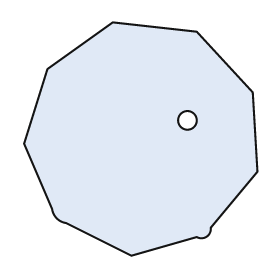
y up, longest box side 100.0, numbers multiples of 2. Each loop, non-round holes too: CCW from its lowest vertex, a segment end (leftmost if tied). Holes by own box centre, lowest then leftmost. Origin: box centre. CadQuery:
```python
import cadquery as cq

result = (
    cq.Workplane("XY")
    .moveTo(-4.0, -50.0)
    .lineTo(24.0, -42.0)
    .threePointArc((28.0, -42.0), (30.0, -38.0))
    .lineTo(50.0, -14.0)
    .lineTo(48.0, 20.0)
    .lineTo(24.0, 46.0)
    .lineTo(-12.0, 50.0)
    .lineTo(-40.0, 30.0)
    .lineTo(-50.0, -2.0)
    .lineTo(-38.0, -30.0)
    .threePointArc((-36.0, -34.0), (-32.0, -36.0))
    .close()
    .moveTo(20.0, 8.0)
    .circle(4.0)
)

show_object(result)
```